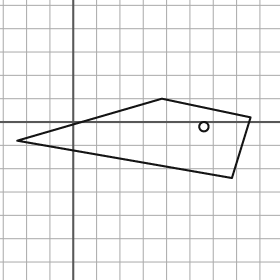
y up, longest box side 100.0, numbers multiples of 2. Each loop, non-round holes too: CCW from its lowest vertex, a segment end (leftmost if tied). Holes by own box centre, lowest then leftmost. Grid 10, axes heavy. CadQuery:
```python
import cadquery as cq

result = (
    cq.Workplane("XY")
    .moveTo(68.0, -24.0)
    .lineTo(76.0, 2.0)
    .lineTo(38.0, 10.0)
    .lineTo(-24.0, -8.0)
    .close()
    .moveTo(56.0, -2.0)
    .circle(2.0)
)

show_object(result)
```